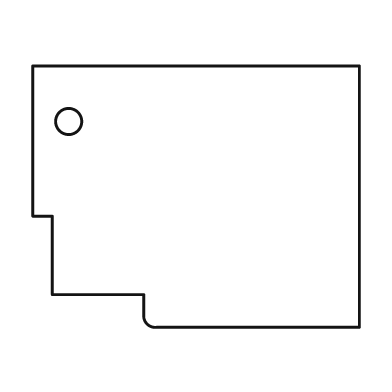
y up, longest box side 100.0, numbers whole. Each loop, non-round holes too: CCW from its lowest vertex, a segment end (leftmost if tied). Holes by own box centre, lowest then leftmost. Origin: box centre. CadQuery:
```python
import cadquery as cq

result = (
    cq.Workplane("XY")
    .moveTo(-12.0, -40.0)
    .lineTo(50.0, -40.0)
    .lineTo(50.0, 40.0)
    .lineTo(-50.0, 40.0)
    .lineTo(-50.0, -6.0)
    .lineTo(-44.0, -6.0)
    .lineTo(-44.0, -30.0)
    .lineTo(-16.0, -30.0)
    .lineTo(-16.0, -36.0)
    .threePointArc((-15.0, -39.0), (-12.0, -40.0))
    .close()
    .moveTo(-39.0, 23.0)
    .circle(4.0)
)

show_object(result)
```